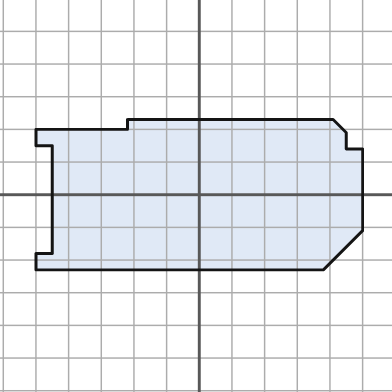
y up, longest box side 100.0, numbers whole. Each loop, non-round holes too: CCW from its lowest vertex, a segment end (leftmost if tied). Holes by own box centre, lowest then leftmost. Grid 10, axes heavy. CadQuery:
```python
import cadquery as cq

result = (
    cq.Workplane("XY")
    .moveTo(-50.0, -23.0)
    .lineTo(38.0, -23.0)
    .lineTo(50.0, -11.0)
    .lineTo(50.0, 14.0)
    .lineTo(45.0, 14.0)
    .lineTo(45.0, 19.0)
    .lineTo(41.0, 23.0)
    .lineTo(-22.0, 23.0)
    .lineTo(-22.0, 20.0)
    .lineTo(-50.0, 20.0)
    .lineTo(-50.0, 15.0)
    .lineTo(-45.0, 15.0)
    .lineTo(-45.0, -18.0)
    .lineTo(-50.0, -18.0)
    .close()
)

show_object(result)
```